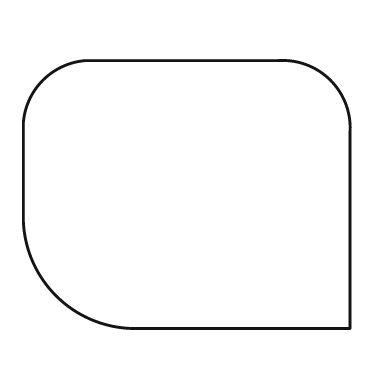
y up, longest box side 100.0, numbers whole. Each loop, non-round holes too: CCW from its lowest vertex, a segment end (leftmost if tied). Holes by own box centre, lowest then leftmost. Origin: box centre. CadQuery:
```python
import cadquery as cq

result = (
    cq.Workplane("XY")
    .moveTo(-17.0, -41.0)
    .lineTo(50.0, -41.0)
    .lineTo(50.0, 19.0)
    .threePointArc((44.0, 35.0), (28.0, 41.0))
    .lineTo(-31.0, 41.0)
    .threePointArc((-44.0, 35.0), (-50.0, 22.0))
    .lineTo(-50.0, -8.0)
    .threePointArc((-40.0, -31.0), (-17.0, -41.0))
    .close()
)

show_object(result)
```